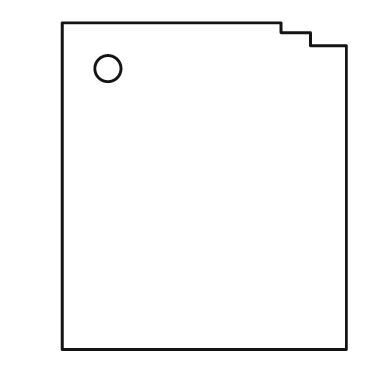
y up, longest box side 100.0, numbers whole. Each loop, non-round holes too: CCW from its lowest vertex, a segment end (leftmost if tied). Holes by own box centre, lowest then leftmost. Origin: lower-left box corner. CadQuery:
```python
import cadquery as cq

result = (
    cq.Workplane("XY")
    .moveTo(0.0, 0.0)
    .lineTo(87.0, 0.0)
    .lineTo(87.0, 93.0)
    .lineTo(76.0, 93.0)
    .lineTo(76.0, 97.0)
    .lineTo(67.0, 97.0)
    .lineTo(67.0, 100.0)
    .lineTo(0.0, 100.0)
    .close()
    .moveTo(14.0, 86.0)
    .circle(4.0)
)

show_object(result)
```